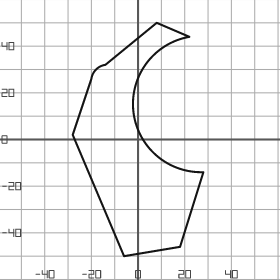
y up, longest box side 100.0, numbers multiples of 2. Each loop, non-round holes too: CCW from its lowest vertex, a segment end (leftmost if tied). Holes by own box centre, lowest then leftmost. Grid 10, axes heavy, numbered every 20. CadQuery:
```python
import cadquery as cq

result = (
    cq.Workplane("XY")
    .moveTo(-6.0, -50.0)
    .lineTo(18.0, -46.0)
    .lineTo(28.0, -14.0)
    .threePointArc((-2.0, 12.0), (22.0, 44.0))
    .lineTo(8.0, 50.0)
    .lineTo(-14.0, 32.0)
    .threePointArc((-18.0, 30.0), (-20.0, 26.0))
    .lineTo(-28.0, 2.0)
    .close()
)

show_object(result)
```